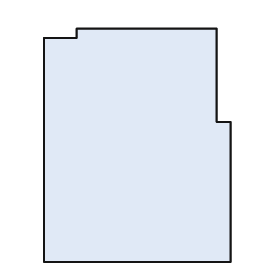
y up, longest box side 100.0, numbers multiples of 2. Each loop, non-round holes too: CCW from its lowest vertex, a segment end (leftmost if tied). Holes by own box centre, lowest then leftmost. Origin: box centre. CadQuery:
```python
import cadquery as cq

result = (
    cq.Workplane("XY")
    .moveTo(-40.0, -50.0)
    .lineTo(40.0, -50.0)
    .lineTo(40.0, 10.0)
    .lineTo(34.0, 10.0)
    .lineTo(34.0, 50.0)
    .lineTo(-26.0, 50.0)
    .lineTo(-26.0, 46.0)
    .lineTo(-40.0, 46.0)
    .close()
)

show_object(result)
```